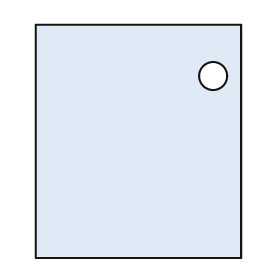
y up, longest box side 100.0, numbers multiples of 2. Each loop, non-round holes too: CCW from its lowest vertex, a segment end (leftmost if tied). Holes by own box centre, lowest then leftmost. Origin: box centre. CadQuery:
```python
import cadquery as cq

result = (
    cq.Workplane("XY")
    .moveTo(-44.0, -50.0)
    .lineTo(44.0, -50.0)
    .lineTo(44.0, 50.0)
    .lineTo(-44.0, 50.0)
    .close()
    .moveTo(32.0, 28.0)
    .circle(6.0)
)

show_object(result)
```